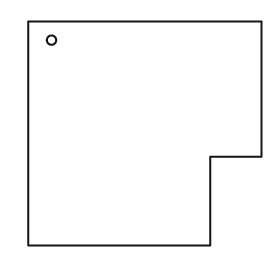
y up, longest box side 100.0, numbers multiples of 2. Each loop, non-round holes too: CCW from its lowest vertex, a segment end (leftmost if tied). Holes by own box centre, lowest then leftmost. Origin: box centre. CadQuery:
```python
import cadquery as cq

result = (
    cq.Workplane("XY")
    .moveTo(-50.0, -48.0)
    .lineTo(28.0, -48.0)
    .lineTo(28.0, -10.0)
    .lineTo(50.0, -10.0)
    .lineTo(50.0, 48.0)
    .lineTo(-50.0, 48.0)
    .close()
    .moveTo(-40.0, 40.0)
    .circle(2.0)
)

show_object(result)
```